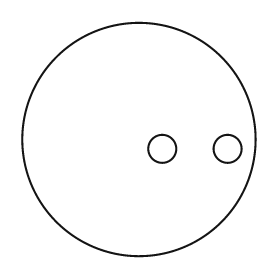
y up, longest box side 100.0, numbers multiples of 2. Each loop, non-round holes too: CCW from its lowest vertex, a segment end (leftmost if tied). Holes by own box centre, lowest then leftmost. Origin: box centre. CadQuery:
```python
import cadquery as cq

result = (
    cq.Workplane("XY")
    .moveTo(0.0, 0.0)
    .circle(50.0)
    .moveTo(10.0, -4.0)
    .circle(6.0)
    .moveTo(38.0, -4.0)
    .circle(6.0)
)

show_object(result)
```